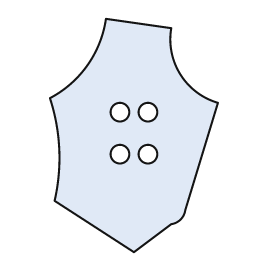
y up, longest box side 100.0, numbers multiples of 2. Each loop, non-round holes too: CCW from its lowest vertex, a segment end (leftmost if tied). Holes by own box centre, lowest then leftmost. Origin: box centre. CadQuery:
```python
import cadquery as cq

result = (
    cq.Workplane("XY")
    .moveTo(0.0, -50.0)
    .lineTo(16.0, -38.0)
    .threePointArc((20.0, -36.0), (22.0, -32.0))
    .lineTo(36.0, 14.0)
    .threePointArc((20.0, 26.0), (16.0, 46.0))
    .lineTo(-12.0, 50.0)
    .threePointArc((-20.0, 30.0), (-36.0, 16.0))
    .threePointArc((-32.0, -6.0), (-34.0, -28.0))
    .close()
    .moveTo(-6.0, -8.0)
    .circle(4.0)
    .moveTo(6.0, -8.0)
    .circle(4.0)
    .moveTo(-6.0, 10.0)
    .circle(4.0)
    .moveTo(6.0, 10.0)
    .circle(4.0)
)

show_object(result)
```